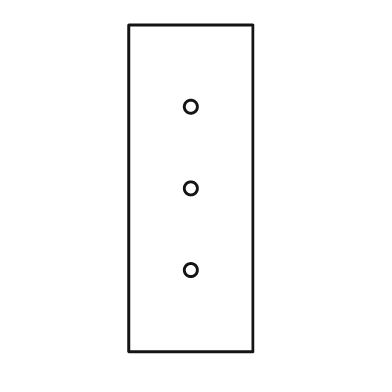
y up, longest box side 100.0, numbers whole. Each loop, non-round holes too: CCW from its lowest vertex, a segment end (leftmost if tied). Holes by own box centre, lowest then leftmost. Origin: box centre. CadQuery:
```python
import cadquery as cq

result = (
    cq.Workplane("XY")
    .moveTo(-19.0, -50.0)
    .lineTo(19.0, -50.0)
    .lineTo(19.0, 50.0)
    .lineTo(-19.0, 50.0)
    .close()
    .moveTo(0.0, -25.0)
    .circle(2.0)
    .moveTo(0.0, 0.0)
    .circle(2.0)
    .moveTo(0.0, 25.0)
    .circle(2.0)
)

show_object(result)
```